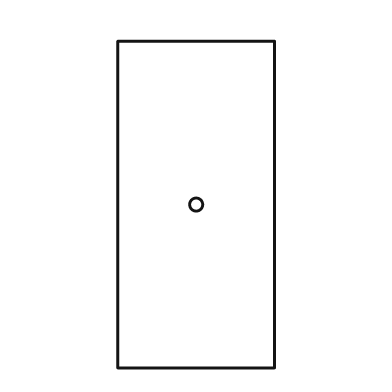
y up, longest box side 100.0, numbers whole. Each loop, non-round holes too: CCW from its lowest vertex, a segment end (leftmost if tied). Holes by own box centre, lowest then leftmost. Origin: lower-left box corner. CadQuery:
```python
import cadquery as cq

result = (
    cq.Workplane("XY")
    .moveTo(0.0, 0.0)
    .lineTo(48.0, 0.0)
    .lineTo(48.0, 100.0)
    .lineTo(0.0, 100.0)
    .close()
    .moveTo(24.0, 50.0)
    .circle(2.0)
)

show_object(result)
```